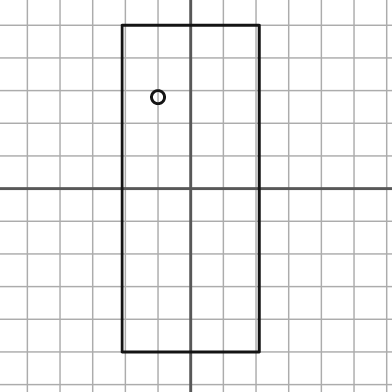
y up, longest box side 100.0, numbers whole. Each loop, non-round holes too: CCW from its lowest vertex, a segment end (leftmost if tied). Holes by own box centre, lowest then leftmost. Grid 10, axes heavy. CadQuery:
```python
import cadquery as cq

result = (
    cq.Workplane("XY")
    .moveTo(-21.0, -50.0)
    .lineTo(21.0, -50.0)
    .lineTo(21.0, 50.0)
    .lineTo(-21.0, 50.0)
    .close()
    .moveTo(-10.0, 28.0)
    .circle(2.0)
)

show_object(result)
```